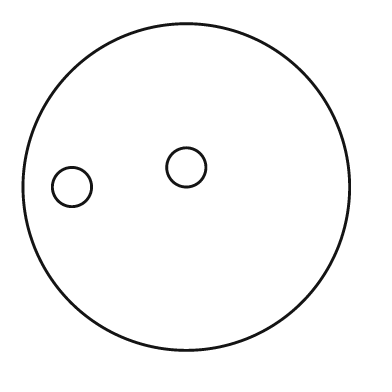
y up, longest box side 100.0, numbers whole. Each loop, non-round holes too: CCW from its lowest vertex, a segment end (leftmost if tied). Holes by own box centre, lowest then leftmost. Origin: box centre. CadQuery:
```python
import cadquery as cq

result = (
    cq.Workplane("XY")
    .moveTo(0.0, 0.0)
    .circle(50.0)
    .moveTo(-35.0, 0.0)
    .circle(6.0)
    .moveTo(0.0, 6.0)
    .circle(6.0)
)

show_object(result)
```